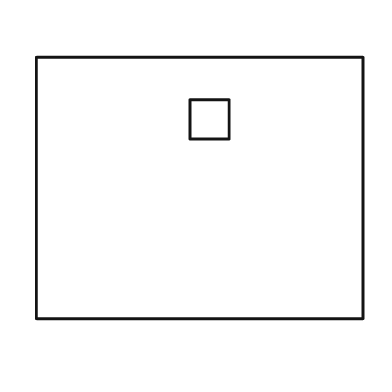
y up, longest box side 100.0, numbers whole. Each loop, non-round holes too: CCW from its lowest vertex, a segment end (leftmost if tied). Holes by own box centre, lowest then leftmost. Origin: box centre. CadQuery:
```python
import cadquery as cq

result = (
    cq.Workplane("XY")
    .moveTo(-50.0, -40.0)
    .lineTo(50.0, -40.0)
    .lineTo(50.0, 40.0)
    .lineTo(-50.0, 40.0)
    .close()
    .moveTo(-3.0, 15.0)
    .lineTo(9.0, 15.0)
    .lineTo(9.0, 27.0)
    .lineTo(-3.0, 27.0)
    .close()
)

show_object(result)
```